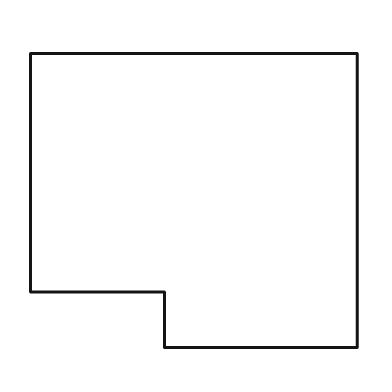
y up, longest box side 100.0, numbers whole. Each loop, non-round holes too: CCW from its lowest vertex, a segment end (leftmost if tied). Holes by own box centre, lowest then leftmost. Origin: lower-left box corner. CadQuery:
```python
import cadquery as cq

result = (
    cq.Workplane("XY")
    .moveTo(41.0, 0.0)
    .lineTo(100.0, 0.0)
    .lineTo(100.0, 90.0)
    .lineTo(0.0, 90.0)
    .lineTo(0.0, 17.0)
    .lineTo(41.0, 17.0)
    .close()
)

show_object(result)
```